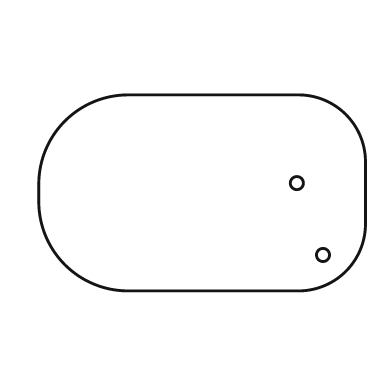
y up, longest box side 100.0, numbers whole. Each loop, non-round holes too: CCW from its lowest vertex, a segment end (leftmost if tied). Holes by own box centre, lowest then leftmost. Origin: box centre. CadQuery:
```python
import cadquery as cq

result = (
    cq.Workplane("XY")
    .moveTo(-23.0, -30.0)
    .lineTo(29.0, -30.0)
    .threePointArc((44.0, -24.0), (50.0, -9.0))
    .lineTo(50.0, 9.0)
    .threePointArc((44.0, 24.0), (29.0, 30.0))
    .lineTo(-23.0, 30.0)
    .threePointArc((-42.0, 22.0), (-50.0, 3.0))
    .lineTo(-50.0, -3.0)
    .threePointArc((-42.0, -22.0), (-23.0, -30.0))
    .close()
    .moveTo(37.0, -19.0)
    .circle(2.0)
    .moveTo(29.0, 3.0)
    .circle(2.0)
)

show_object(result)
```